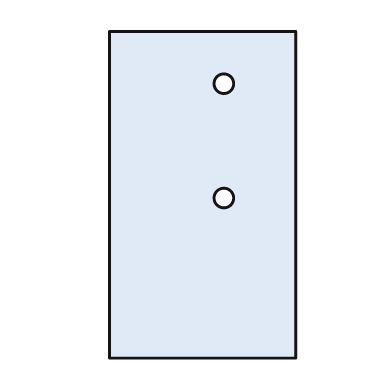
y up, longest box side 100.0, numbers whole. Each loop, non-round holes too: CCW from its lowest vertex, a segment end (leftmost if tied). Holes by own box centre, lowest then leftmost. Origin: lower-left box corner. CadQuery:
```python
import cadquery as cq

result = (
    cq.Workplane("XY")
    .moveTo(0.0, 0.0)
    .lineTo(57.0, 0.0)
    .lineTo(57.0, 100.0)
    .lineTo(0.0, 100.0)
    .close()
    .moveTo(35.0, 49.0)
    .circle(3.0)
    .moveTo(35.0, 84.0)
    .circle(3.0)
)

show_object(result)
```